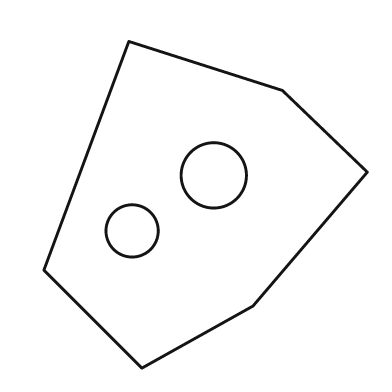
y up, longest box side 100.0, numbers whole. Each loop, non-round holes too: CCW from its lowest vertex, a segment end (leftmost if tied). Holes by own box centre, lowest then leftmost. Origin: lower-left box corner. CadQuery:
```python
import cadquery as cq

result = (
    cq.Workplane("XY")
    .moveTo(30.0, 0.0)
    .lineTo(64.0, 19.0)
    .lineTo(99.0, 60.0)
    .lineTo(73.0, 85.0)
    .lineTo(26.0, 100.0)
    .lineTo(0.0, 30.0)
    .close()
    .moveTo(27.0, 42.0)
    .circle(8.0)
    .moveTo(52.0, 59.0)
    .circle(10.0)
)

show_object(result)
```